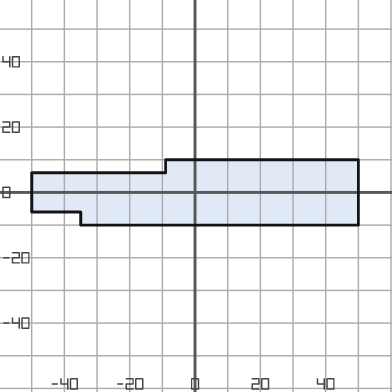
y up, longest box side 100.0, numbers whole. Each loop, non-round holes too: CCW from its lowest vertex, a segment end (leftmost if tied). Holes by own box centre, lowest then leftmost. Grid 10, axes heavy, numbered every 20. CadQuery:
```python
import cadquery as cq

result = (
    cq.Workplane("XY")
    .moveTo(-35.0, -10.0)
    .lineTo(50.0, -10.0)
    .lineTo(50.0, 10.0)
    .lineTo(-9.0, 10.0)
    .lineTo(-9.0, 6.0)
    .lineTo(-50.0, 6.0)
    .lineTo(-50.0, -6.0)
    .lineTo(-35.0, -6.0)
    .close()
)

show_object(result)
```